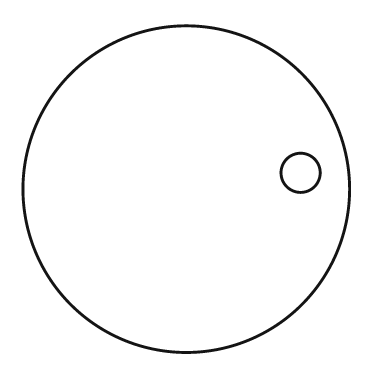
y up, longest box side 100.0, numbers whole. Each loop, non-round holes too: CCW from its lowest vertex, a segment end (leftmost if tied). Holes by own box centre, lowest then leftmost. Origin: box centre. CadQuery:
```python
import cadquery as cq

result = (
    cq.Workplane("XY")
    .moveTo(0.0, 0.0)
    .circle(50.0)
    .moveTo(35.0, 5.0)
    .circle(6.0)
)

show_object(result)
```